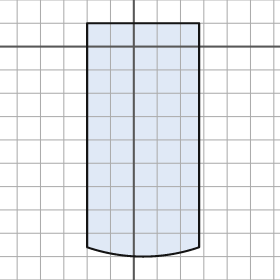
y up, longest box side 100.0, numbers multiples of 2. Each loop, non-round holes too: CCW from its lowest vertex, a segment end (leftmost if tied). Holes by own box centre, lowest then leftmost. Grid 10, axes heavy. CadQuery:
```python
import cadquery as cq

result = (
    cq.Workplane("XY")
    .moveTo(-20.0, -86.0)
    .threePointArc((4.0, -90.0), (28.0, -86.0))
    .lineTo(28.0, 10.0)
    .lineTo(-20.0, 10.0)
    .close()
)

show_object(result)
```